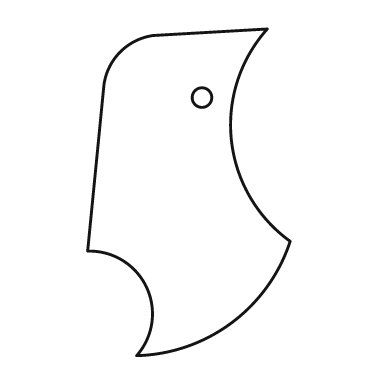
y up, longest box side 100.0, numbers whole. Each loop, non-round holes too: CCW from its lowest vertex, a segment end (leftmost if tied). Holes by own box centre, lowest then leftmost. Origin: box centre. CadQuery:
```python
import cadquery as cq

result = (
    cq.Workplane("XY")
    .moveTo(-16.0, -50.0)
    .threePointArc((13.0, -40.0), (31.0, -15.0))
    .threePointArc((13.0, 16.0), (24.0, 50.0))
    .lineTo(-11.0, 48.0)
    .threePointArc((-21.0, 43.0), (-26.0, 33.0))
    .lineTo(-31.0, -18.0)
    .threePointArc((-13.0, -29.0), (-16.0, -50.0))
    .close()
    .moveTo(4.0, 29.0)
    .circle(3.0)
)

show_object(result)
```